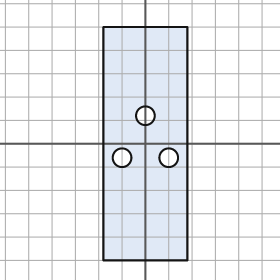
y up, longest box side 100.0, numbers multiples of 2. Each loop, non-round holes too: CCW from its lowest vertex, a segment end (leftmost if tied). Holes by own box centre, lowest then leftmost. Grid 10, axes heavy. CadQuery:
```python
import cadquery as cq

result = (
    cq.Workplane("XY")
    .moveTo(-18.0, -50.0)
    .lineTo(18.0, -50.0)
    .lineTo(18.0, 50.0)
    .lineTo(-18.0, 50.0)
    .close()
    .moveTo(-10.0, -6.0)
    .circle(4.0)
    .moveTo(10.0, -6.0)
    .circle(4.0)
    .moveTo(0.0, 12.0)
    .circle(4.0)
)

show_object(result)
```